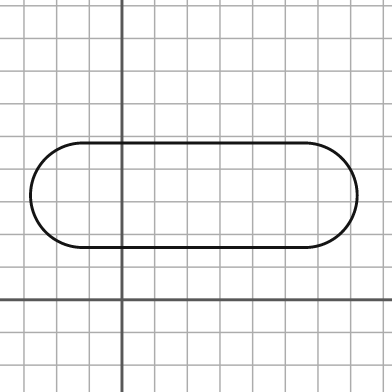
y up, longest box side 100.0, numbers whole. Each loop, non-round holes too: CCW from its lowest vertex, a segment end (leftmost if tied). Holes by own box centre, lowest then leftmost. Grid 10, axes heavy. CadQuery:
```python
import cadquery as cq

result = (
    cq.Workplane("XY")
    .moveTo(-12.0, 16.0)
    .lineTo(56.0, 16.0)
    .threePointArc((72.0, 32.0), (56.0, 48.0))
    .lineTo(-12.0, 48.0)
    .threePointArc((-28.0, 32.0), (-12.0, 16.0))
    .close()
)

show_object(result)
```